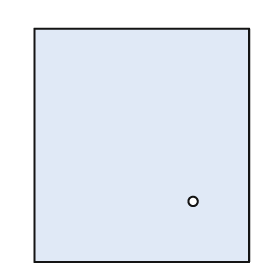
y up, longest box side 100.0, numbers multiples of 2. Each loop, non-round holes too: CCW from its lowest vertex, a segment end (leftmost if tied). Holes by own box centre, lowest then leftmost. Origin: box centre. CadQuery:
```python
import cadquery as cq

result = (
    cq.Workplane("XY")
    .moveTo(-46.0, -50.0)
    .lineTo(46.0, -50.0)
    .lineTo(46.0, 50.0)
    .lineTo(-46.0, 50.0)
    .close()
    .moveTo(22.0, -24.0)
    .circle(2.0)
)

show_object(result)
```